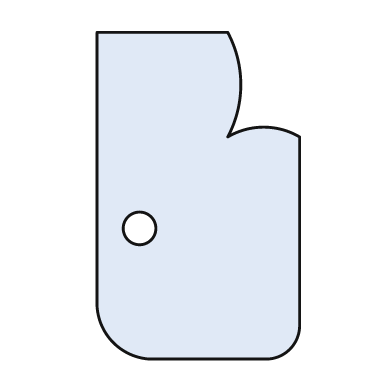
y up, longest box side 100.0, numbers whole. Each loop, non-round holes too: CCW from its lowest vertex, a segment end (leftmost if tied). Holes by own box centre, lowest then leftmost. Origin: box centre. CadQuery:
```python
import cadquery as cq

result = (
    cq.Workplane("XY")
    .moveTo(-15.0, -50.0)
    .lineTo(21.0, -50.0)
    .threePointArc((28.0, -47.0), (31.0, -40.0))
    .lineTo(31.0, 18.0)
    .threePointArc((20.0, 21.0), (9.0, 18.0))
    .threePointArc((13.0, 34.0), (9.0, 50.0))
    .lineTo(-31.0, 50.0)
    .lineTo(-31.0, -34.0)
    .threePointArc((-26.0, -45.0), (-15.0, -50.0))
    .close()
    .moveTo(-18.0, -10.0)
    .circle(5.0)
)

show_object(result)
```